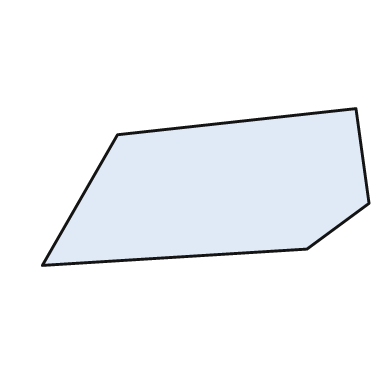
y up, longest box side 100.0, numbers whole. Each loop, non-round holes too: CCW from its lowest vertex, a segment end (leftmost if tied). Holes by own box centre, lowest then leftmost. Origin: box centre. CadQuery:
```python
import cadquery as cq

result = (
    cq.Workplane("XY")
    .moveTo(-50.0, -24.0)
    .lineTo(31.0, -19.0)
    .lineTo(50.0, -5.0)
    .lineTo(46.0, 24.0)
    .lineTo(-27.0, 16.0)
    .close()
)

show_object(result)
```